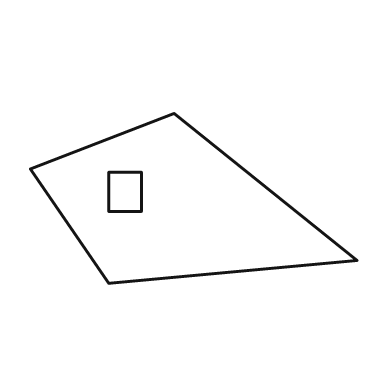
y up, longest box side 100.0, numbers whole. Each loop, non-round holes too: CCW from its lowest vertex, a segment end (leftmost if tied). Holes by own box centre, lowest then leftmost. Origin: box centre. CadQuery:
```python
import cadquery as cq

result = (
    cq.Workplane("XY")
    .moveTo(-26.0, -26.0)
    .lineTo(50.0, -19.0)
    .lineTo(-6.0, 26.0)
    .lineTo(-50.0, 9.0)
    .close()
    .moveTo(-26.0, -4.0)
    .lineTo(-16.0, -4.0)
    .lineTo(-16.0, 8.0)
    .lineTo(-26.0, 8.0)
    .close()
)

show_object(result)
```